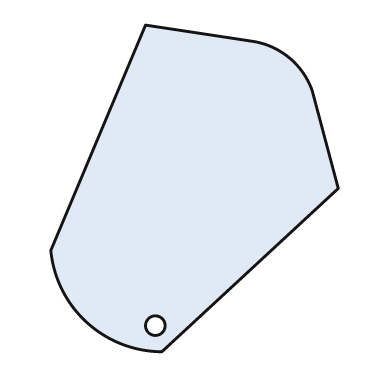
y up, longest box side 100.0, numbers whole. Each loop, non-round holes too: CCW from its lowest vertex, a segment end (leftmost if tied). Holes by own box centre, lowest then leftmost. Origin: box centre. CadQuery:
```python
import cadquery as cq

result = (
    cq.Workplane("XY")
    .moveTo(-10.0, -50.0)
    .lineTo(44.0, 0.0)
    .lineTo(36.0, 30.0)
    .threePointArc((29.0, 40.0), (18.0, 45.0))
    .lineTo(-15.0, 50.0)
    .lineTo(-44.0, -19.0)
    .threePointArc((-33.0, -41.0), (-10.0, -50.0))
    .close()
    .moveTo(-12.0, -42.0)
    .circle(3.0)
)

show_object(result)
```